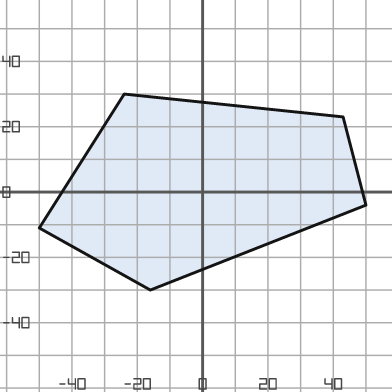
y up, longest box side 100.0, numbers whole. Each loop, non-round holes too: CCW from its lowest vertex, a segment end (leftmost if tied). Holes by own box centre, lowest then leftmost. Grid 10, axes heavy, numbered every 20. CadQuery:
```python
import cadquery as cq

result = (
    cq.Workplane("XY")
    .moveTo(-16.0, -30.0)
    .lineTo(50.0, -4.0)
    .lineTo(43.0, 23.0)
    .lineTo(-24.0, 30.0)
    .lineTo(-50.0, -11.0)
    .close()
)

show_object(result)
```